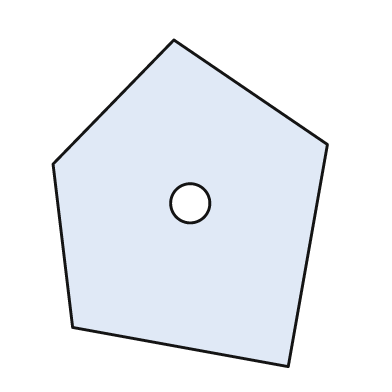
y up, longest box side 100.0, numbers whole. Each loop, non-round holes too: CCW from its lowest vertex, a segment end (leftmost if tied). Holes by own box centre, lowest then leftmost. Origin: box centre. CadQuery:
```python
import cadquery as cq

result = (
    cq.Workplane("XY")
    .moveTo(30.0, -50.0)
    .lineTo(42.0, 18.0)
    .lineTo(-5.0, 50.0)
    .lineTo(-42.0, 12.0)
    .lineTo(-36.0, -38.0)
    .close()
    .moveTo(0.0, 0.0)
    .circle(6.0)
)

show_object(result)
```